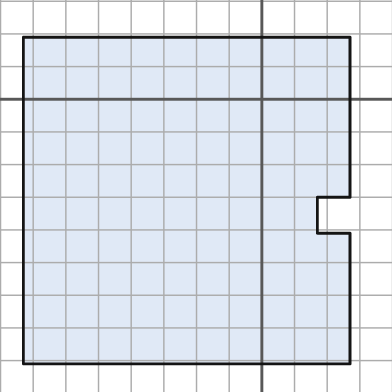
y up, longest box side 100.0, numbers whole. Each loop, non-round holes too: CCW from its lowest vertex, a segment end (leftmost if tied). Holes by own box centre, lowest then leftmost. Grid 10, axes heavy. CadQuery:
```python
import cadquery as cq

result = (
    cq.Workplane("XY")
    .moveTo(-73.0, -81.0)
    .lineTo(27.0, -81.0)
    .lineTo(27.0, -41.0)
    .lineTo(17.0, -41.0)
    .lineTo(17.0, -30.0)
    .lineTo(27.0, -30.0)
    .lineTo(27.0, 19.0)
    .lineTo(-73.0, 19.0)
    .close()
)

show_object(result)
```